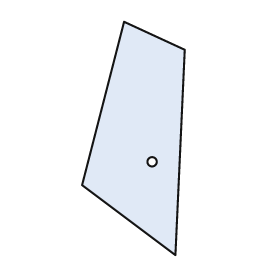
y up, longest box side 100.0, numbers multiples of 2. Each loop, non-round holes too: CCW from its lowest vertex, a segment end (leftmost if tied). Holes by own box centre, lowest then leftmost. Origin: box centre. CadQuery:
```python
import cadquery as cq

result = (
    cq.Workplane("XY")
    .moveTo(18.0, -50.0)
    .lineTo(22.0, 38.0)
    .lineTo(-4.0, 50.0)
    .lineTo(-22.0, -20.0)
    .close()
    .moveTo(8.0, -10.0)
    .circle(2.0)
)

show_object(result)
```